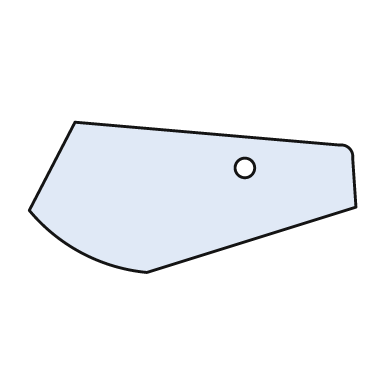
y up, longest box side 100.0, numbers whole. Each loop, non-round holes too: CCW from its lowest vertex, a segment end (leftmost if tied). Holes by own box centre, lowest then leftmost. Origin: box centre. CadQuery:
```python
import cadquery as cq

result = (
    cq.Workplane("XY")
    .moveTo(-14.0, -23.0)
    .lineTo(50.0, -3.0)
    .lineTo(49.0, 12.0)
    .threePointArc((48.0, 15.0), (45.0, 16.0))
    .lineTo(-36.0, 23.0)
    .lineTo(-50.0, -4.0)
    .threePointArc((-34.0, -17.0), (-14.0, -23.0))
    .close()
    .moveTo(16.0, 9.0)
    .circle(3.0)
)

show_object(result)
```